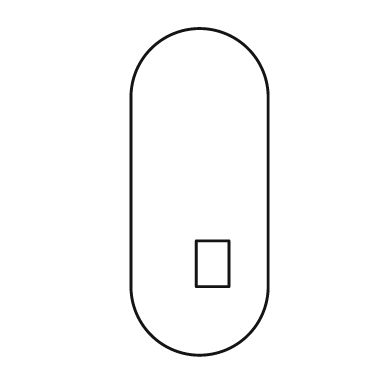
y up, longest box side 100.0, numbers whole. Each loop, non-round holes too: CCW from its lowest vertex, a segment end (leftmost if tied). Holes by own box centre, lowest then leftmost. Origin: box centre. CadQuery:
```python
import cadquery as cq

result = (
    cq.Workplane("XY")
    .moveTo(-21.0, -29.0)
    .threePointArc((0.0, -50.0), (21.0, -29.0))
    .lineTo(21.0, 29.0)
    .threePointArc((0.0, 50.0), (-21.0, 29.0))
    .close()
    .moveTo(-1.0, -29.0)
    .lineTo(9.0, -29.0)
    .lineTo(9.0, -15.0)
    .lineTo(-1.0, -15.0)
    .close()
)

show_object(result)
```